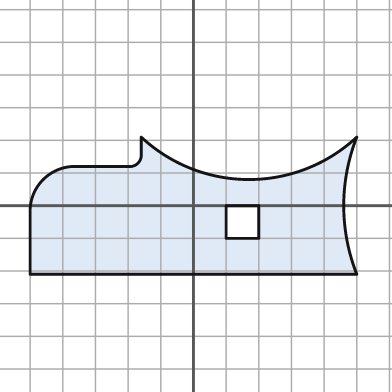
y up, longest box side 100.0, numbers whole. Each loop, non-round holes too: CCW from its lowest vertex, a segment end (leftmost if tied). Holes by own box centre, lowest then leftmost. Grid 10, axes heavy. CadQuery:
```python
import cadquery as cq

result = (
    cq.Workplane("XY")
    .moveTo(-50.0, -21.0)
    .lineTo(50.0, -21.0)
    .threePointArc((46.0, 0.0), (50.0, 21.0))
    .threePointArc((17.0, 8.0), (-16.0, 21.0))
    .lineTo(-16.0, 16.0)
    .threePointArc((-17.0, 13.0), (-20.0, 12.0))
    .lineTo(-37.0, 12.0)
    .threePointArc((-46.0, 8.0), (-50.0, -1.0))
    .close()
    .moveTo(10.0, -10.0)
    .lineTo(20.0, -10.0)
    .lineTo(20.0, 0.0)
    .lineTo(10.0, 0.0)
    .close()
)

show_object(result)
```